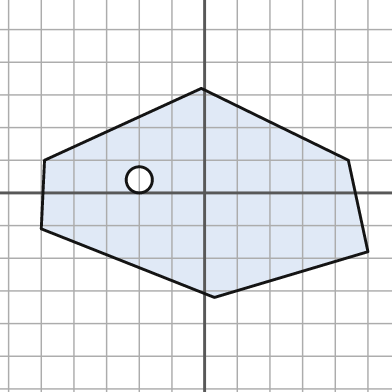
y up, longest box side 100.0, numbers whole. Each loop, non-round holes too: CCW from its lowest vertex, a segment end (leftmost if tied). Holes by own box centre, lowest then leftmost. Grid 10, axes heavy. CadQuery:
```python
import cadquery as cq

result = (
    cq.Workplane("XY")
    .moveTo(3.0, -32.0)
    .lineTo(50.0, -18.0)
    .lineTo(44.0, 10.0)
    .lineTo(-1.0, 32.0)
    .lineTo(-49.0, 10.0)
    .lineTo(-50.0, -11.0)
    .close()
    .moveTo(-20.0, 4.0)
    .circle(4.0)
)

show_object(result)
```